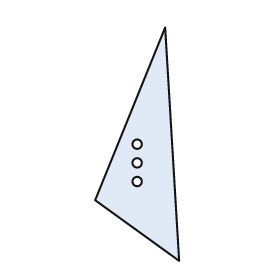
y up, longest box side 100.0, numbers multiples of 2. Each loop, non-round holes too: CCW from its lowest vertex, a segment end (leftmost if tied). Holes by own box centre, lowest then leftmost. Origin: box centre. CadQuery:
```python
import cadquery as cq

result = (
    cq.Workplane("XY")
    .moveTo(18.0, -50.0)
    .lineTo(12.0, 50.0)
    .lineTo(-18.0, -24.0)
    .close()
    .moveTo(0.0, -16.0)
    .circle(2.0)
    .moveTo(0.0, -8.0)
    .circle(2.0)
    .moveTo(0.0, 0.0)
    .circle(2.0)
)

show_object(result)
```